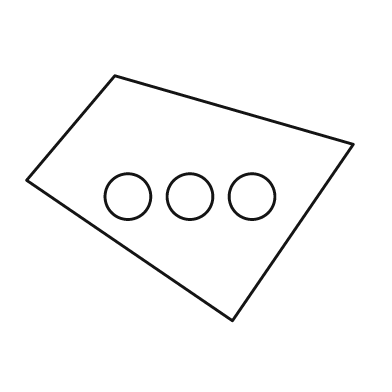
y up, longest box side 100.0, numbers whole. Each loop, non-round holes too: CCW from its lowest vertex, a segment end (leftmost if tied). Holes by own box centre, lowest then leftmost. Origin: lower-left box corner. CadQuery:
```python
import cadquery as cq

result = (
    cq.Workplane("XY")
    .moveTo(63.0, 0.0)
    .lineTo(100.0, 54.0)
    .lineTo(27.0, 75.0)
    .lineTo(0.0, 43.0)
    .close()
    .moveTo(31.0, 38.0)
    .circle(7.0)
    .moveTo(50.0, 38.0)
    .circle(7.0)
    .moveTo(69.0, 38.0)
    .circle(7.0)
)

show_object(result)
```